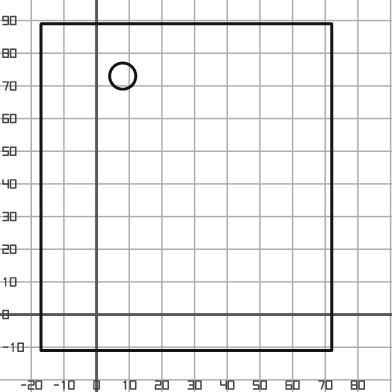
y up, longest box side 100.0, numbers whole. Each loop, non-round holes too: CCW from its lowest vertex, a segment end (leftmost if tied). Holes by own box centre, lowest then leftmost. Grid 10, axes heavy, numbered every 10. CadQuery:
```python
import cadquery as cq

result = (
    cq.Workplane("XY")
    .moveTo(-17.0, -11.0)
    .lineTo(72.0, -11.0)
    .lineTo(72.0, 89.0)
    .lineTo(-17.0, 89.0)
    .close()
    .moveTo(8.0, 73.0)
    .circle(4.0)
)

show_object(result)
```